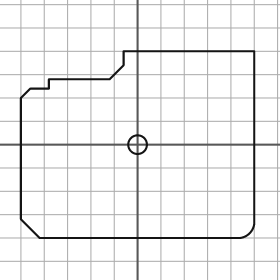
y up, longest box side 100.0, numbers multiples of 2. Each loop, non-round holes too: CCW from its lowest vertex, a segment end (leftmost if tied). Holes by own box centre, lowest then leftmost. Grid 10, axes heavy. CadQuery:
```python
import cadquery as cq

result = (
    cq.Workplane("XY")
    .moveTo(-42.0, -40.0)
    .lineTo(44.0, -40.0)
    .threePointArc((48.0, -38.0), (50.0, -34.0))
    .lineTo(50.0, 40.0)
    .lineTo(-6.0, 40.0)
    .lineTo(-6.0, 34.0)
    .lineTo(-12.0, 28.0)
    .lineTo(-38.0, 28.0)
    .lineTo(-38.0, 24.0)
    .lineTo(-46.0, 24.0)
    .lineTo(-50.0, 20.0)
    .lineTo(-50.0, -32.0)
    .close()
    .moveTo(0.0, 0.0)
    .circle(4.0)
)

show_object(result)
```